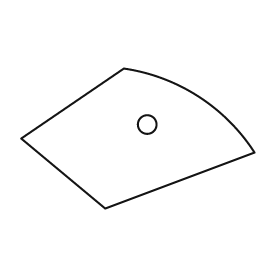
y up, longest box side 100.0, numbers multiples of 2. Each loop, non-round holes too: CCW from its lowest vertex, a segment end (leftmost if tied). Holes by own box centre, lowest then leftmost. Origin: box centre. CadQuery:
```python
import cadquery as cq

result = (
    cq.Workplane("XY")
    .moveTo(-14.0, -30.0)
    .lineTo(50.0, -6.0)
    .threePointArc((26.0, 18.0), (-6.0, 30.0))
    .lineTo(-50.0, 0.0)
    .close()
    .moveTo(4.0, 6.0)
    .circle(4.0)
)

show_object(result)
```